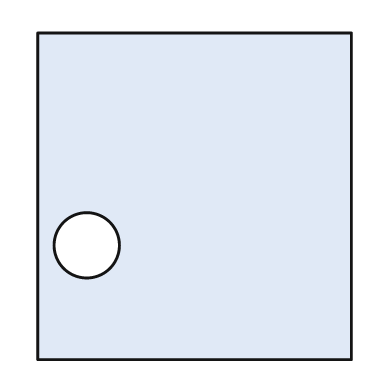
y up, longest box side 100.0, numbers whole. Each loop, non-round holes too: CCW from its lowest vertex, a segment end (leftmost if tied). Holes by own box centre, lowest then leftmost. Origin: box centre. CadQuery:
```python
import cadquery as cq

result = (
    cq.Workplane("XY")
    .moveTo(-48.0, -50.0)
    .lineTo(48.0, -50.0)
    .lineTo(48.0, 50.0)
    .lineTo(-48.0, 50.0)
    .close()
    .moveTo(-33.0, -15.0)
    .circle(10.0)
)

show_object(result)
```